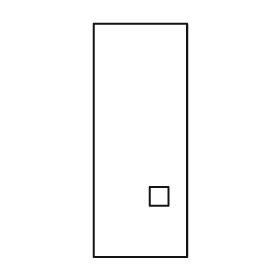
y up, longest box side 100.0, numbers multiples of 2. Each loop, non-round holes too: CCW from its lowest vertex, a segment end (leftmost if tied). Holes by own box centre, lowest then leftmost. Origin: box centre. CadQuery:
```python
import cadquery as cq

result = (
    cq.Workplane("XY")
    .moveTo(-20.0, -50.0)
    .lineTo(20.0, -50.0)
    .lineTo(20.0, 50.0)
    .lineTo(-20.0, 50.0)
    .close()
    .moveTo(4.0, -28.0)
    .lineTo(12.0, -28.0)
    .lineTo(12.0, -20.0)
    .lineTo(4.0, -20.0)
    .close()
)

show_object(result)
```